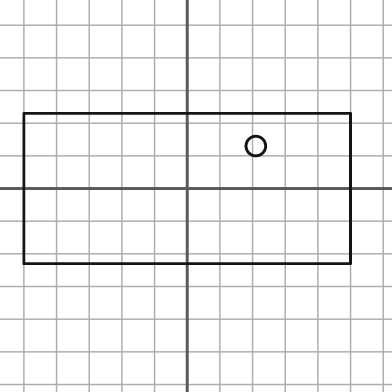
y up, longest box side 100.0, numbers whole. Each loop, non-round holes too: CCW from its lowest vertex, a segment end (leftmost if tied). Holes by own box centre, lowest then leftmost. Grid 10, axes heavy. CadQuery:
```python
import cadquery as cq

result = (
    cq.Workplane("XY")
    .moveTo(-50.0, -23.0)
    .lineTo(50.0, -23.0)
    .lineTo(50.0, 23.0)
    .lineTo(-50.0, 23.0)
    .close()
    .moveTo(21.0, 13.0)
    .circle(3.0)
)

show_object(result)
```